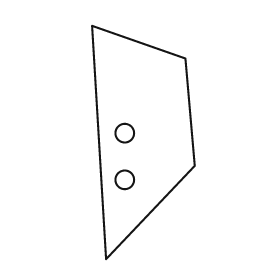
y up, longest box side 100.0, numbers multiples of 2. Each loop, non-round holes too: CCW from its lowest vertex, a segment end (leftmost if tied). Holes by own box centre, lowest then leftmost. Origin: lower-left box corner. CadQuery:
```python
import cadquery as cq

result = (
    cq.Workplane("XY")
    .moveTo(6.0, 0.0)
    .lineTo(44.0, 40.0)
    .lineTo(40.0, 86.0)
    .lineTo(0.0, 100.0)
    .close()
    .moveTo(14.0, 34.0)
    .circle(4.0)
    .moveTo(14.0, 54.0)
    .circle(4.0)
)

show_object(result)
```